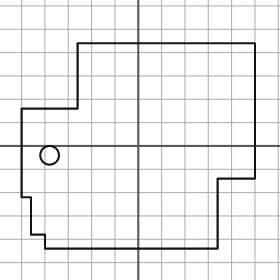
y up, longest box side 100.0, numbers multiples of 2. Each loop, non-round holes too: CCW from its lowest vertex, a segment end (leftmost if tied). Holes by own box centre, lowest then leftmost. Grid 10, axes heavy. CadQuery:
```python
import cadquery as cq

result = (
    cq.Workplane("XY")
    .moveTo(-40.0, -44.0)
    .lineTo(34.0, -44.0)
    .lineTo(34.0, -14.0)
    .lineTo(50.0, -14.0)
    .lineTo(50.0, 44.0)
    .lineTo(-26.0, 44.0)
    .lineTo(-26.0, 16.0)
    .lineTo(-50.0, 16.0)
    .lineTo(-50.0, -22.0)
    .lineTo(-46.0, -22.0)
    .lineTo(-46.0, -38.0)
    .lineTo(-40.0, -38.0)
    .close()
    .moveTo(-38.0, -4.0)
    .circle(4.0)
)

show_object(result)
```